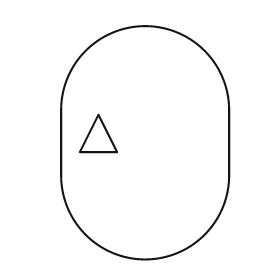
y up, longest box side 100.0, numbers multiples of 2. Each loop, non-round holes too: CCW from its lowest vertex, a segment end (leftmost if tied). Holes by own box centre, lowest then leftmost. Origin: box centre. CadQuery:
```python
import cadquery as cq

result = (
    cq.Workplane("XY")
    .moveTo(-36.0, -14.0)
    .threePointArc((0.0, -50.0), (36.0, -14.0))
    .lineTo(36.0, 14.0)
    .threePointArc((0.0, 50.0), (-36.0, 14.0))
    .close()
    .moveTo(-28.0, -4.0)
    .lineTo(-12.0, -4.0)
    .lineTo(-20.0, 12.0)
    .close()
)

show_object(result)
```